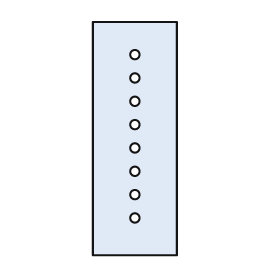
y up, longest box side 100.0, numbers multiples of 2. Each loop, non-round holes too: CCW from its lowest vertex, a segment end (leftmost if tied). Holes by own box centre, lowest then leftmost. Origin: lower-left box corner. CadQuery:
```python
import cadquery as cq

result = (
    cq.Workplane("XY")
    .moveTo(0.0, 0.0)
    .lineTo(36.0, 0.0)
    .lineTo(36.0, 100.0)
    .lineTo(0.0, 100.0)
    .close()
    .moveTo(18.0, 16.0)
    .circle(2.0)
    .moveTo(18.0, 26.0)
    .circle(2.0)
    .moveTo(18.0, 36.0)
    .circle(2.0)
    .moveTo(18.0, 46.0)
    .circle(2.0)
    .moveTo(18.0, 56.0)
    .circle(2.0)
    .moveTo(18.0, 66.0)
    .circle(2.0)
    .moveTo(18.0, 76.0)
    .circle(2.0)
    .moveTo(18.0, 86.0)
    .circle(2.0)
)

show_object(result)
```